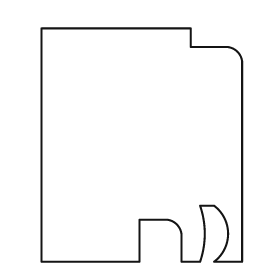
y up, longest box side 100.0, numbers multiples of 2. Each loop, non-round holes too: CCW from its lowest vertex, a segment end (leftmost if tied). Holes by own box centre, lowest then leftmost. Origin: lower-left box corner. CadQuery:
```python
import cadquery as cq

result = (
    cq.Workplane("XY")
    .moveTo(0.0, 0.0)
    .lineTo(42.0, 0.0)
    .lineTo(42.0, 18.0)
    .lineTo(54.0, 18.0)
    .threePointArc((58.0, 16.0), (60.0, 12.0))
    .lineTo(60.0, 0.0)
    .lineTo(68.0, 0.0)
    .threePointArc((70.0, 12.0), (68.0, 24.0))
    .lineTo(74.0, 24.0)
    .threePointArc((80.0, 12.0), (74.0, 0.0))
    .lineTo(86.0, 0.0)
    .lineTo(86.0, 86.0)
    .threePointArc((84.0, 90.0), (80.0, 92.0))
    .lineTo(64.0, 92.0)
    .lineTo(64.0, 100.0)
    .lineTo(0.0, 100.0)
    .close()
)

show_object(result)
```